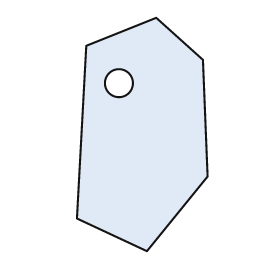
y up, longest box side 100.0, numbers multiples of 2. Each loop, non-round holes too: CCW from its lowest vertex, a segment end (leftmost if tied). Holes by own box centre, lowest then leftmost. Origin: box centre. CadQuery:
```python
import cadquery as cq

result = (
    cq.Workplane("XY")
    .moveTo(2.0, -50.0)
    .lineTo(28.0, -18.0)
    .lineTo(26.0, 32.0)
    .lineTo(6.0, 50.0)
    .lineTo(-24.0, 38.0)
    .lineTo(-28.0, -36.0)
    .close()
    .moveTo(-10.0, 22.0)
    .circle(6.0)
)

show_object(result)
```